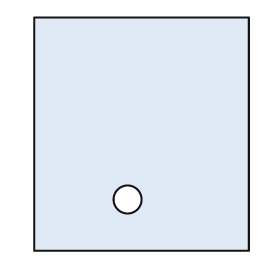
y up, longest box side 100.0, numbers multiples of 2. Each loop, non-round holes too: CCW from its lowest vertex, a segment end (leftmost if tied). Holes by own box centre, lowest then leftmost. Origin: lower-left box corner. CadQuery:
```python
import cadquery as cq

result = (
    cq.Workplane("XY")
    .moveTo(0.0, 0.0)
    .lineTo(92.0, 0.0)
    .lineTo(92.0, 100.0)
    .lineTo(0.0, 100.0)
    .close()
    .moveTo(40.0, 22.0)
    .circle(6.0)
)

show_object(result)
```